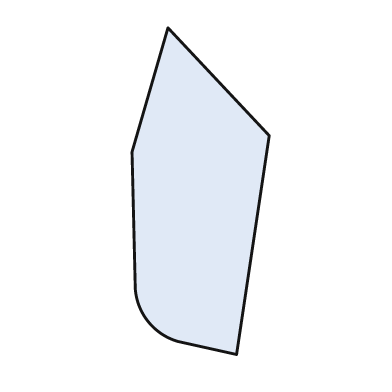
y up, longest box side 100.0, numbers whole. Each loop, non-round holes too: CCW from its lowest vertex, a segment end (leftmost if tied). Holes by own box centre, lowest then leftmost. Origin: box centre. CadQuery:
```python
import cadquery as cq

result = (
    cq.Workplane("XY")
    .moveTo(11.0, -50.0)
    .lineTo(21.0, 17.0)
    .lineTo(-10.0, 50.0)
    .lineTo(-21.0, 12.0)
    .lineTo(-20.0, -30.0)
    .threePointArc((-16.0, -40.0), (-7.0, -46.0))
    .close()
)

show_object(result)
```